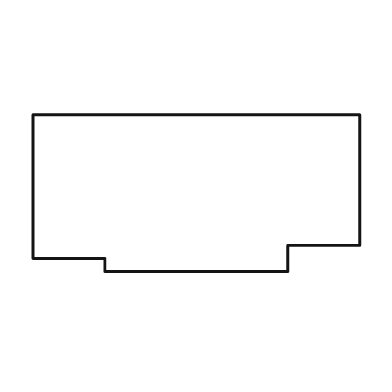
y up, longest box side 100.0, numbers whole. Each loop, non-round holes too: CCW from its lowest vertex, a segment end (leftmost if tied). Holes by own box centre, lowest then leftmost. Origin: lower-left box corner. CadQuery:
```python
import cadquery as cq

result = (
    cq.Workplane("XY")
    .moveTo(22.0, 0.0)
    .lineTo(78.0, 0.0)
    .lineTo(78.0, 8.0)
    .lineTo(100.0, 8.0)
    .lineTo(100.0, 48.0)
    .lineTo(0.0, 48.0)
    .lineTo(0.0, 4.0)
    .lineTo(22.0, 4.0)
    .close()
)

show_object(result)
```